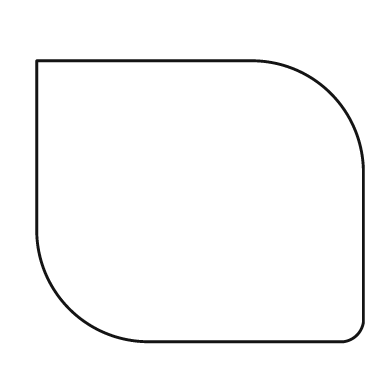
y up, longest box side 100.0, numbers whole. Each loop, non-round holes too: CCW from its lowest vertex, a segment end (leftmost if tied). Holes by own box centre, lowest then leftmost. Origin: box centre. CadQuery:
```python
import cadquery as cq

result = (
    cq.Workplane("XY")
    .moveTo(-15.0, -43.0)
    .lineTo(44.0, -43.0)
    .threePointArc((48.0, -41.0), (50.0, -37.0))
    .lineTo(50.0, 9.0)
    .threePointArc((40.0, 33.0), (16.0, 43.0))
    .lineTo(-50.0, 43.0)
    .lineTo(-50.0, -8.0)
    .threePointArc((-40.0, -33.0), (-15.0, -43.0))
    .close()
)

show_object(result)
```